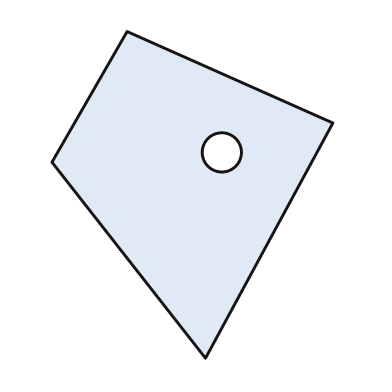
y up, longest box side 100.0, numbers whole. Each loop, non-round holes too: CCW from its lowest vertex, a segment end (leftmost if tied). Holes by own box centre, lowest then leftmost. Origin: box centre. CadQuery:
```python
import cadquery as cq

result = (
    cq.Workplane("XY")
    .moveTo(4.0, -50.0)
    .lineTo(43.0, 22.0)
    .lineTo(-20.0, 50.0)
    .lineTo(-43.0, 10.0)
    .close()
    .moveTo(9.0, 13.0)
    .circle(6.0)
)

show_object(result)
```